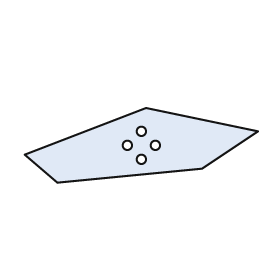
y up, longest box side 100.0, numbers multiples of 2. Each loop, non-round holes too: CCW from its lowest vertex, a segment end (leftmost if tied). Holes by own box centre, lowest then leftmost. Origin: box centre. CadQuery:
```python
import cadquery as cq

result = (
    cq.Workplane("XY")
    .moveTo(-36.0, -16.0)
    .lineTo(26.0, -10.0)
    .lineTo(50.0, 6.0)
    .lineTo(2.0, 16.0)
    .lineTo(-50.0, -4.0)
    .close()
    .moveTo(0.0, -6.0)
    .circle(2.0)
    .moveTo(-6.0, 0.0)
    .circle(2.0)
    .moveTo(6.0, 0.0)
    .circle(2.0)
    .moveTo(0.0, 6.0)
    .circle(2.0)
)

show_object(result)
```